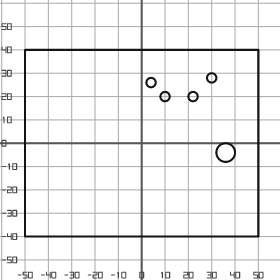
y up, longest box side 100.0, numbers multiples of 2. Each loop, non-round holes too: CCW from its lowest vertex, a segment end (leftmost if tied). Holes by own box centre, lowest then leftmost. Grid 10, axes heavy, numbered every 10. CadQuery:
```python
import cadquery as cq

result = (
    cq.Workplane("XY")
    .moveTo(-50.0, -40.0)
    .lineTo(50.0, -40.0)
    .lineTo(50.0, 40.0)
    .lineTo(-50.0, 40.0)
    .close()
    .moveTo(36.0, -4.0)
    .circle(4.0)
    .moveTo(10.0, 20.0)
    .circle(2.0)
    .moveTo(22.0, 20.0)
    .circle(2.0)
    .moveTo(4.0, 26.0)
    .circle(2.0)
    .moveTo(30.0, 28.0)
    .circle(2.0)
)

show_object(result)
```